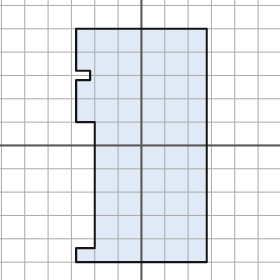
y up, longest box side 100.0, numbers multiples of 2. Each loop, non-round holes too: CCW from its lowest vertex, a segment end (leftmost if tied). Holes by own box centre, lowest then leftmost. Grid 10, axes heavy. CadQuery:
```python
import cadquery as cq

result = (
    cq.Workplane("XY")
    .moveTo(-28.0, -50.0)
    .lineTo(28.0, -50.0)
    .lineTo(28.0, 50.0)
    .lineTo(-28.0, 50.0)
    .lineTo(-28.0, 32.0)
    .lineTo(-22.0, 32.0)
    .lineTo(-22.0, 28.0)
    .lineTo(-28.0, 28.0)
    .lineTo(-28.0, 10.0)
    .lineTo(-20.0, 10.0)
    .lineTo(-20.0, -44.0)
    .lineTo(-28.0, -44.0)
    .close()
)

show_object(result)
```